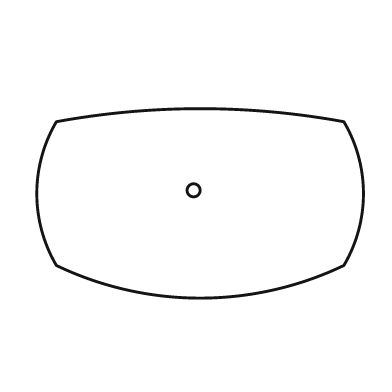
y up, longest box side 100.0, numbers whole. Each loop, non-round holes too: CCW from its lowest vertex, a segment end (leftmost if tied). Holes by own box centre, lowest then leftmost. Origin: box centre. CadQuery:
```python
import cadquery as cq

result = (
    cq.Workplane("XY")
    .moveTo(-44.0, -19.0)
    .threePointArc((0.0, -29.0), (44.0, -19.0))
    .threePointArc((50.0, 3.0), (44.0, 25.0))
    .threePointArc((0.0, 29.0), (-44.0, 25.0))
    .threePointArc((-50.0, 3.0), (-44.0, -19.0))
    .close()
    .moveTo(-2.0, 4.0)
    .circle(2.0)
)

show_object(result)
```